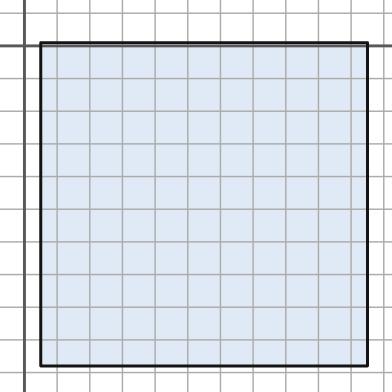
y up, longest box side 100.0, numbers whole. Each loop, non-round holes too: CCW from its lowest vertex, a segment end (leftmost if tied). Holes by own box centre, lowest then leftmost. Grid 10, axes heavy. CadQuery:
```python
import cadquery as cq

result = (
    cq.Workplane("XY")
    .moveTo(5.0, -98.0)
    .lineTo(105.0, -98.0)
    .lineTo(105.0, 1.0)
    .lineTo(5.0, 1.0)
    .close()
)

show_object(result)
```